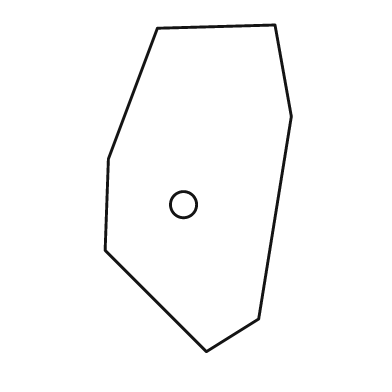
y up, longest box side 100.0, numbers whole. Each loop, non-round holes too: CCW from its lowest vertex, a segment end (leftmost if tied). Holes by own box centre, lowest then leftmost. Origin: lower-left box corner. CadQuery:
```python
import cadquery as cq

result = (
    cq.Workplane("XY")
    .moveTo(31.0, 0.0)
    .lineTo(47.0, 10.0)
    .lineTo(57.0, 72.0)
    .lineTo(52.0, 100.0)
    .lineTo(16.0, 99.0)
    .lineTo(1.0, 59.0)
    .lineTo(0.0, 31.0)
    .close()
    .moveTo(24.0, 45.0)
    .circle(4.0)
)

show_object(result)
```